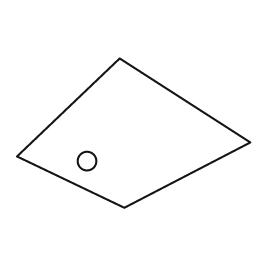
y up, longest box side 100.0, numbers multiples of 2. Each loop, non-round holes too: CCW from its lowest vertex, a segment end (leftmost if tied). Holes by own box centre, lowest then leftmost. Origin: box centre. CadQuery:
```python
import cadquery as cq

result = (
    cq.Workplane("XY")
    .moveTo(-4.0, -32.0)
    .lineTo(50.0, -4.0)
    .lineTo(-6.0, 32.0)
    .lineTo(-50.0, -10.0)
    .close()
    .moveTo(-20.0, -12.0)
    .circle(4.0)
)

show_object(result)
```